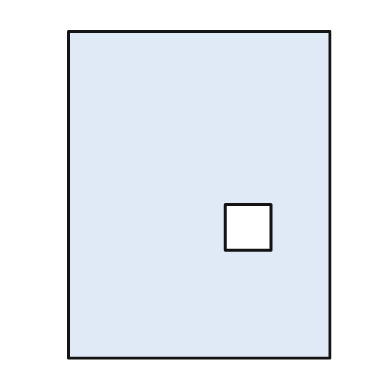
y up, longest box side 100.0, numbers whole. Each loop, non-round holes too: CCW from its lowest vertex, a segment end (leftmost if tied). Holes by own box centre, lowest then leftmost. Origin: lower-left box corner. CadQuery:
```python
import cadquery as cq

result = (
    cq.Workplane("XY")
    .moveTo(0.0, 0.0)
    .lineTo(80.0, 0.0)
    .lineTo(80.0, 100.0)
    .lineTo(0.0, 100.0)
    .close()
    .moveTo(48.0, 33.0)
    .lineTo(62.0, 33.0)
    .lineTo(62.0, 47.0)
    .lineTo(48.0, 47.0)
    .close()
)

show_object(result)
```